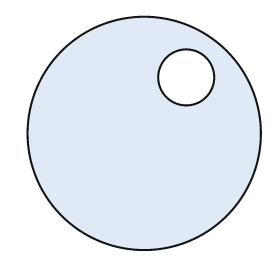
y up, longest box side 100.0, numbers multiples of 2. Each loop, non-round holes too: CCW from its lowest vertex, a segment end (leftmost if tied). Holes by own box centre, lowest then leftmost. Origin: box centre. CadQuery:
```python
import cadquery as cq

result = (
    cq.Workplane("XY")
    .moveTo(0.0, 0.0)
    .circle(50.0)
    .moveTo(18.0, 24.0)
    .circle(12.0)
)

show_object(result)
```